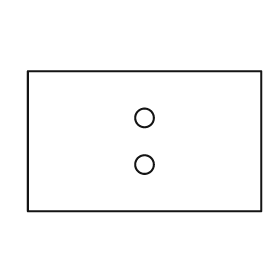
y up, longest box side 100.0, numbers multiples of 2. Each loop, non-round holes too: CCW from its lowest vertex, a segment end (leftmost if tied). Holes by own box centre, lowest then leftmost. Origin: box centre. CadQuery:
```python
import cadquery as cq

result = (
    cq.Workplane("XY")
    .moveTo(-50.0, -30.0)
    .lineTo(50.0, -30.0)
    .lineTo(50.0, 30.0)
    .lineTo(-50.0, 30.0)
    .close()
    .moveTo(0.0, -10.0)
    .circle(4.0)
    .moveTo(0.0, 10.0)
    .circle(4.0)
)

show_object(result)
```